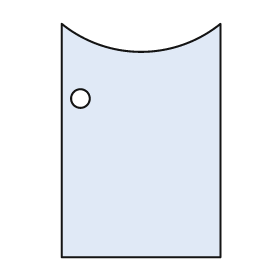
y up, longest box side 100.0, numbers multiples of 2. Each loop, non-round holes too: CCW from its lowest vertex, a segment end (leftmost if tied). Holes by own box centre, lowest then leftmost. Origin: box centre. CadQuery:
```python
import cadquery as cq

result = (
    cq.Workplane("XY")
    .moveTo(-34.0, -50.0)
    .lineTo(34.0, -50.0)
    .lineTo(34.0, 50.0)
    .threePointArc((0.0, 38.0), (-34.0, 50.0))
    .close()
    .moveTo(-26.0, 18.0)
    .circle(4.0)
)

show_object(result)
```